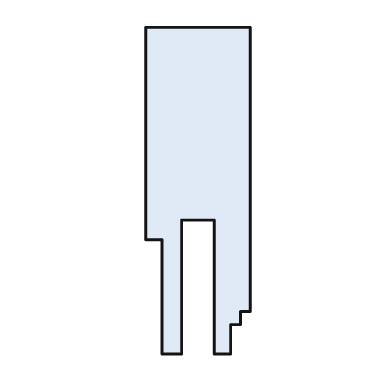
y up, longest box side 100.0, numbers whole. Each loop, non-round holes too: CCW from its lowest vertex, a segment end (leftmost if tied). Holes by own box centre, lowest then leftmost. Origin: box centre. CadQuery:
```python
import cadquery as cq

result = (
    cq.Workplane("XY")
    .moveTo(-11.0, -50.0)
    .lineTo(-5.0, -50.0)
    .lineTo(-5.0, -9.0)
    .lineTo(5.0, -9.0)
    .lineTo(5.0, -50.0)
    .lineTo(10.0, -50.0)
    .lineTo(10.0, -41.0)
    .lineTo(13.0, -41.0)
    .lineTo(13.0, -37.0)
    .lineTo(16.0, -37.0)
    .lineTo(16.0, 50.0)
    .lineTo(-16.0, 50.0)
    .lineTo(-16.0, -15.0)
    .lineTo(-11.0, -15.0)
    .close()
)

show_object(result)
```